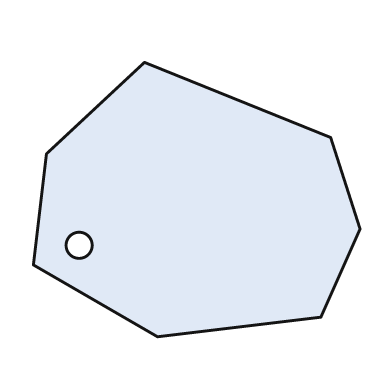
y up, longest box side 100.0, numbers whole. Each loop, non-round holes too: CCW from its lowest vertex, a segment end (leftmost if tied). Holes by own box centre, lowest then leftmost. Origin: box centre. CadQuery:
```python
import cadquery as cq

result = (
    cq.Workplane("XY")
    .moveTo(-12.0, -42.0)
    .lineTo(38.0, -36.0)
    .lineTo(50.0, -9.0)
    .lineTo(41.0, 19.0)
    .lineTo(-16.0, 42.0)
    .lineTo(-46.0, 14.0)
    .lineTo(-50.0, -20.0)
    .close()
    .moveTo(-36.0, -14.0)
    .circle(4.0)
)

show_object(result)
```